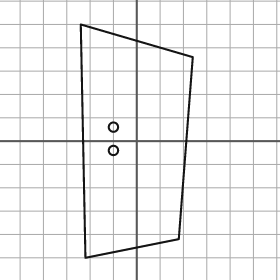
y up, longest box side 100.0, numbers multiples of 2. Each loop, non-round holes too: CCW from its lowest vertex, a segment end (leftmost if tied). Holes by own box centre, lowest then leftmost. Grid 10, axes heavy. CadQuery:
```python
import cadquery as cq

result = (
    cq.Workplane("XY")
    .moveTo(-22.0, -50.0)
    .lineTo(18.0, -42.0)
    .lineTo(24.0, 36.0)
    .lineTo(-24.0, 50.0)
    .close()
    .moveTo(-10.0, -4.0)
    .circle(2.0)
    .moveTo(-10.0, 6.0)
    .circle(2.0)
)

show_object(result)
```